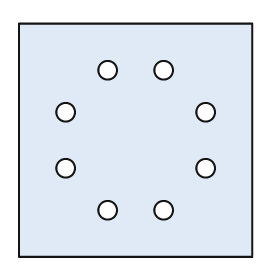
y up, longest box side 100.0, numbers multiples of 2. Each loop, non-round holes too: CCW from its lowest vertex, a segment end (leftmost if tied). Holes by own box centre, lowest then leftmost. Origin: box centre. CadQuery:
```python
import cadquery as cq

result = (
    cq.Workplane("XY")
    .moveTo(-50.0, -50.0)
    .lineTo(50.0, -50.0)
    .lineTo(50.0, 50.0)
    .lineTo(-50.0, 50.0)
    .close()
    .moveTo(-12.0, -30.0)
    .circle(4.0)
    .moveTo(12.0, -30.0)
    .circle(4.0)
    .moveTo(-30.0, -12.0)
    .circle(4.0)
    .moveTo(30.0, -12.0)
    .circle(4.0)
    .moveTo(-30.0, 12.0)
    .circle(4.0)
    .moveTo(30.0, 12.0)
    .circle(4.0)
    .moveTo(-12.0, 30.0)
    .circle(4.0)
    .moveTo(12.0, 30.0)
    .circle(4.0)
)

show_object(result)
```